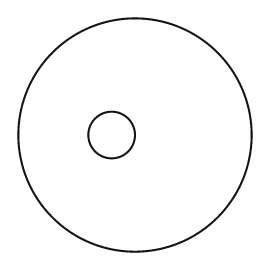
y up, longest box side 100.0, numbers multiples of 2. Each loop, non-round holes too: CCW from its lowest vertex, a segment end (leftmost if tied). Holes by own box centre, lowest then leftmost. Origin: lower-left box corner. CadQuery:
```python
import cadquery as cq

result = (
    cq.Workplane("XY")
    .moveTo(50.0, 50.0)
    .circle(50.0)
    .moveTo(40.0, 50.0)
    .circle(10.0)
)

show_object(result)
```